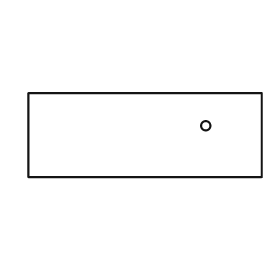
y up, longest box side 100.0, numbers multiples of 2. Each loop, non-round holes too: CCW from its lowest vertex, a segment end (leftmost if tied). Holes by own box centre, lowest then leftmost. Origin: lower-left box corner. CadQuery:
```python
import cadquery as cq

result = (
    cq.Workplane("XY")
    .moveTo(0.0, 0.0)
    .lineTo(100.0, 0.0)
    .lineTo(100.0, 36.0)
    .lineTo(0.0, 36.0)
    .close()
    .moveTo(76.0, 22.0)
    .circle(2.0)
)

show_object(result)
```